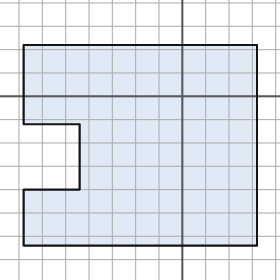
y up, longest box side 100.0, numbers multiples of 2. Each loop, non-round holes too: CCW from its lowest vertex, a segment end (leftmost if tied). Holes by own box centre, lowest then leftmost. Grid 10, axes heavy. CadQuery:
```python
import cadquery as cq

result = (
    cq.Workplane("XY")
    .moveTo(-68.0, -64.0)
    .lineTo(32.0, -64.0)
    .lineTo(32.0, 22.0)
    .lineTo(-68.0, 22.0)
    .lineTo(-68.0, -12.0)
    .lineTo(-44.0, -12.0)
    .lineTo(-44.0, -40.0)
    .lineTo(-68.0, -40.0)
    .close()
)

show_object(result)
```